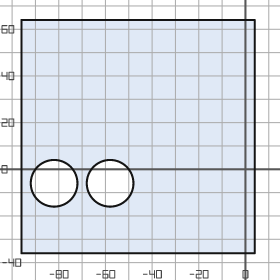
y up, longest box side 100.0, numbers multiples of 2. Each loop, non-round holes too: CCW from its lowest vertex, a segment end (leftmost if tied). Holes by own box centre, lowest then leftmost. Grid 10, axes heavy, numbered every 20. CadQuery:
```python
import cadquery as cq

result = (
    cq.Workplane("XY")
    .moveTo(-96.0, -36.0)
    .lineTo(4.0, -36.0)
    .lineTo(4.0, 64.0)
    .lineTo(-96.0, 64.0)
    .close()
    .moveTo(-82.0, -6.0)
    .circle(10.0)
    .moveTo(-58.0, -6.0)
    .circle(10.0)
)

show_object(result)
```